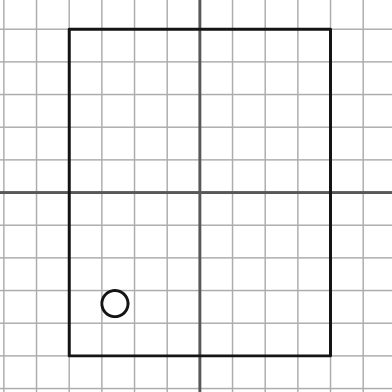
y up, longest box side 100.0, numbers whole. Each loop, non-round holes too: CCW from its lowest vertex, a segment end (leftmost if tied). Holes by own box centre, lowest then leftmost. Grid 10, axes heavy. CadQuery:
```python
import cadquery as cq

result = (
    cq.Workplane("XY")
    .moveTo(-40.0, -50.0)
    .lineTo(40.0, -50.0)
    .lineTo(40.0, 50.0)
    .lineTo(-40.0, 50.0)
    .close()
    .moveTo(-26.0, -34.0)
    .circle(4.0)
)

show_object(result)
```